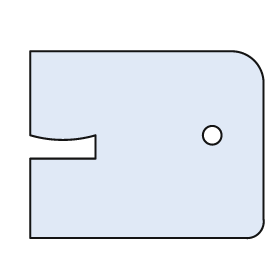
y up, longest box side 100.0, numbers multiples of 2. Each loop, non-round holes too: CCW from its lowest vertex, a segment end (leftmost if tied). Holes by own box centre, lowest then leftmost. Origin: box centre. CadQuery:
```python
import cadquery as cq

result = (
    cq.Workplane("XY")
    .moveTo(-50.0, -40.0)
    .lineTo(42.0, -40.0)
    .threePointArc((48.0, -38.0), (50.0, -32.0))
    .lineTo(50.0, 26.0)
    .threePointArc((46.0, 36.0), (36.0, 40.0))
    .lineTo(-50.0, 40.0)
    .lineTo(-50.0, 4.0)
    .threePointArc((-36.0, 2.0), (-22.0, 4.0))
    .lineTo(-22.0, -6.0)
    .lineTo(-50.0, -6.0)
    .close()
    .moveTo(28.0, 4.0)
    .circle(4.0)
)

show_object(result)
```